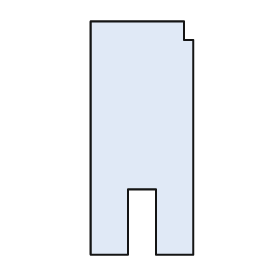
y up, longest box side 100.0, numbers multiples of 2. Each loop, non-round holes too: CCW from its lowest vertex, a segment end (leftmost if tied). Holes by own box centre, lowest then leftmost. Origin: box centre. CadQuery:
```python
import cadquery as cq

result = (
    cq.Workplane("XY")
    .moveTo(-22.0, -50.0)
    .lineTo(-6.0, -50.0)
    .lineTo(-6.0, -22.0)
    .lineTo(6.0, -22.0)
    .lineTo(6.0, -50.0)
    .lineTo(22.0, -50.0)
    .lineTo(22.0, 42.0)
    .lineTo(18.0, 42.0)
    .lineTo(18.0, 50.0)
    .lineTo(-22.0, 50.0)
    .close()
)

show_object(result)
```